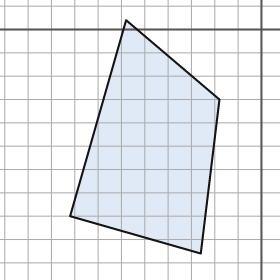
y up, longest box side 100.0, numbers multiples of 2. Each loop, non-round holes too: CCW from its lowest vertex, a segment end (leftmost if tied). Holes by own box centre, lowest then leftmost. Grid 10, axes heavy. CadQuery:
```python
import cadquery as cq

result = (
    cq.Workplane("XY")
    .moveTo(-26.0, -96.0)
    .lineTo(-18.0, -30.0)
    .lineTo(-58.0, 4.0)
    .lineTo(-82.0, -80.0)
    .close()
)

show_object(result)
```